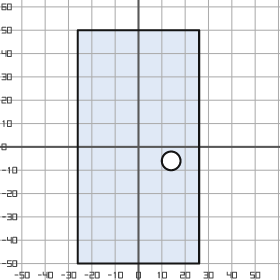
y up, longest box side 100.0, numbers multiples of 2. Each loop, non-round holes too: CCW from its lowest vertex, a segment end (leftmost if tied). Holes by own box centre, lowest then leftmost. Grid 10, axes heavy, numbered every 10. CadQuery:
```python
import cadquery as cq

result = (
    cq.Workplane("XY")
    .moveTo(-26.0, -50.0)
    .lineTo(26.0, -50.0)
    .lineTo(26.0, 50.0)
    .lineTo(-26.0, 50.0)
    .close()
    .moveTo(14.0, -6.0)
    .circle(4.0)
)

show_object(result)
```